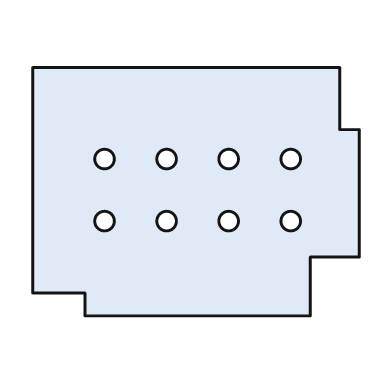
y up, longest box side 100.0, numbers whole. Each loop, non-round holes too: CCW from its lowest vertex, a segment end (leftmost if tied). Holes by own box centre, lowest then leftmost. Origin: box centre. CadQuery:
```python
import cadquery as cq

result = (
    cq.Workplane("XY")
    .moveTo(-34.0, -38.0)
    .lineTo(35.0, -38.0)
    .lineTo(35.0, -20.0)
    .lineTo(50.0, -20.0)
    .lineTo(50.0, 19.0)
    .lineTo(44.0, 19.0)
    .lineTo(44.0, 38.0)
    .lineTo(-50.0, 38.0)
    .lineTo(-50.0, -31.0)
    .lineTo(-34.0, -31.0)
    .close()
    .moveTo(-28.0, -9.0)
    .circle(3.0)
    .moveTo(-9.0, -9.0)
    .circle(3.0)
    .moveTo(10.0, -9.0)
    .circle(3.0)
    .moveTo(29.0, -9.0)
    .circle(3.0)
    .moveTo(-28.0, 10.0)
    .circle(3.0)
    .moveTo(-9.0, 10.0)
    .circle(3.0)
    .moveTo(10.0, 10.0)
    .circle(3.0)
    .moveTo(29.0, 10.0)
    .circle(3.0)
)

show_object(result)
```